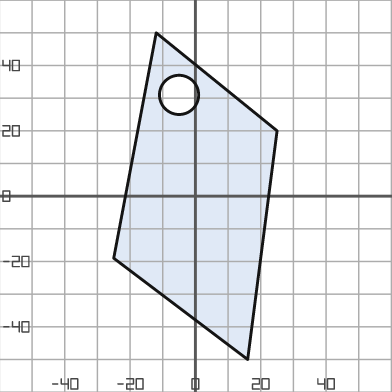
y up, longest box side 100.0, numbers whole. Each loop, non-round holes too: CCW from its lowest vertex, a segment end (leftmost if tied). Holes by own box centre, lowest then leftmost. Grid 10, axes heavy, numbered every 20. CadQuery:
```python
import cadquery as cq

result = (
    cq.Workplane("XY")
    .moveTo(16.0, -50.0)
    .lineTo(25.0, 20.0)
    .lineTo(-12.0, 50.0)
    .lineTo(-25.0, -19.0)
    .close()
    .moveTo(-5.0, 31.0)
    .circle(6.0)
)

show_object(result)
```